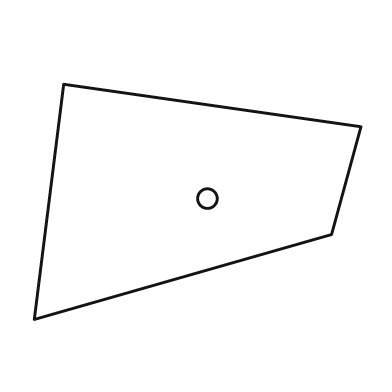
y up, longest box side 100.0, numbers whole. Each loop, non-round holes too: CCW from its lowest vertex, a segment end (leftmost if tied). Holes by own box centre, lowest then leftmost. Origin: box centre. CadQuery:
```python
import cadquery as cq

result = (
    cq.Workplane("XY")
    .moveTo(-50.0, -36.0)
    .lineTo(41.0, -10.0)
    .lineTo(50.0, 23.0)
    .lineTo(-41.0, 36.0)
    .close()
    .moveTo(3.0, 1.0)
    .circle(3.0)
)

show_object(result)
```